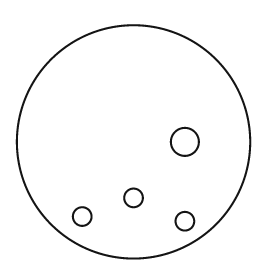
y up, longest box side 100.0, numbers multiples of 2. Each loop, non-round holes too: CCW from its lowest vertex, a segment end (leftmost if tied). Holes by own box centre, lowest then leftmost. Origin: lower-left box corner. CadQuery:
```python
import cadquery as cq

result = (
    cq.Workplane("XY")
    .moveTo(50.0, 50.0)
    .circle(50.0)
    .moveTo(72.0, 16.0)
    .circle(4.0)
    .moveTo(28.0, 18.0)
    .circle(4.0)
    .moveTo(50.0, 26.0)
    .circle(4.0)
    .moveTo(72.0, 50.0)
    .circle(6.0)
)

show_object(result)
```